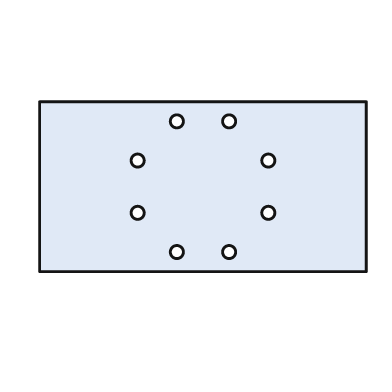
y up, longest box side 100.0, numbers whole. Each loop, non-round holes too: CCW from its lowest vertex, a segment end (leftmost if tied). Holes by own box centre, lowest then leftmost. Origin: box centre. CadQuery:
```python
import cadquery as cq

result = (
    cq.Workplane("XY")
    .moveTo(-50.0, -26.0)
    .lineTo(50.0, -26.0)
    .lineTo(50.0, 26.0)
    .lineTo(-50.0, 26.0)
    .close()
    .moveTo(-8.0, -20.0)
    .circle(2.0)
    .moveTo(8.0, -20.0)
    .circle(2.0)
    .moveTo(-20.0, -8.0)
    .circle(2.0)
    .moveTo(20.0, -8.0)
    .circle(2.0)
    .moveTo(-20.0, 8.0)
    .circle(2.0)
    .moveTo(20.0, 8.0)
    .circle(2.0)
    .moveTo(-8.0, 20.0)
    .circle(2.0)
    .moveTo(8.0, 20.0)
    .circle(2.0)
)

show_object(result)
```